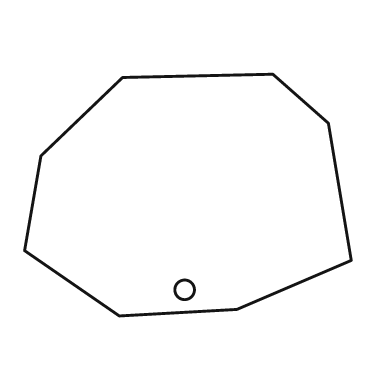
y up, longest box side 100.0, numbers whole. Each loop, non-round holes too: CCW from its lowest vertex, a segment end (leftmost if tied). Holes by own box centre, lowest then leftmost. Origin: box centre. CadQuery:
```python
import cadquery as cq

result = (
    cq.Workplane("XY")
    .moveTo(-21.0, -37.0)
    .lineTo(15.0, -35.0)
    .lineTo(50.0, -20.0)
    .lineTo(43.0, 22.0)
    .lineTo(26.0, 37.0)
    .lineTo(-20.0, 36.0)
    .lineTo(-45.0, 12.0)
    .lineTo(-50.0, -17.0)
    .close()
    .moveTo(-1.0, -29.0)
    .circle(3.0)
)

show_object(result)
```